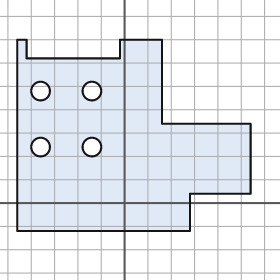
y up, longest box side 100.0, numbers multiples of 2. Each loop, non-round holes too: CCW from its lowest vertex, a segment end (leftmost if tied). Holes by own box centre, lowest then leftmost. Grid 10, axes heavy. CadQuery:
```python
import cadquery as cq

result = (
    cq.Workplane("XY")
    .moveTo(-46.0, -12.0)
    .lineTo(28.0, -12.0)
    .lineTo(28.0, 4.0)
    .lineTo(54.0, 4.0)
    .lineTo(54.0, 34.0)
    .lineTo(16.0, 34.0)
    .lineTo(16.0, 70.0)
    .lineTo(-2.0, 70.0)
    .lineTo(-2.0, 62.0)
    .lineTo(-42.0, 62.0)
    .lineTo(-42.0, 70.0)
    .lineTo(-46.0, 70.0)
    .close()
    .moveTo(-36.0, 24.0)
    .circle(4.0)
    .moveTo(-14.0, 24.0)
    .circle(4.0)
    .moveTo(-36.0, 48.0)
    .circle(4.0)
    .moveTo(-14.0, 48.0)
    .circle(4.0)
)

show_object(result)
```